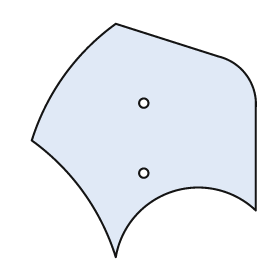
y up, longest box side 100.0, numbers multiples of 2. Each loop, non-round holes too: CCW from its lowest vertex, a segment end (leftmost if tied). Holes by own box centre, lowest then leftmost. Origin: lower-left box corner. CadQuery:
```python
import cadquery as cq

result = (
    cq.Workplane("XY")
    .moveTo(36.0, 0.0)
    .threePointArc((60.0, 28.0), (96.0, 20.0))
    .lineTo(96.0, 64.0)
    .threePointArc((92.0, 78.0), (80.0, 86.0))
    .lineTo(36.0, 100.0)
    .threePointArc((14.0, 78.0), (0.0, 50.0))
    .threePointArc((22.0, 28.0), (36.0, 0.0))
    .close()
    .moveTo(48.0, 36.0)
    .circle(2.0)
    .moveTo(48.0, 66.0)
    .circle(2.0)
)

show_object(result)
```